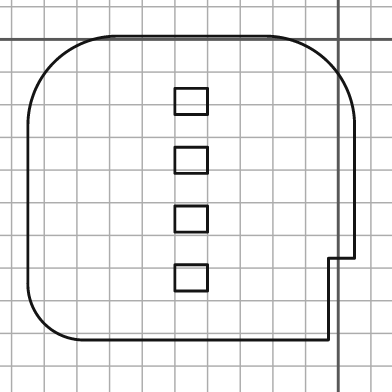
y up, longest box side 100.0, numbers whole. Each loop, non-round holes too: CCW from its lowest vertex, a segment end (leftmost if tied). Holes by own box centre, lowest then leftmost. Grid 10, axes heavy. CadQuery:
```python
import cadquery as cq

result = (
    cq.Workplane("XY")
    .moveTo(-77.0, -92.0)
    .lineTo(-3.0, -92.0)
    .lineTo(-3.0, -67.0)
    .lineTo(5.0, -67.0)
    .lineTo(5.0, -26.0)
    .threePointArc((-3.0, -7.0), (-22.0, 1.0))
    .lineTo(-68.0, 1.0)
    .threePointArc((-87.0, -7.0), (-95.0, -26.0))
    .lineTo(-95.0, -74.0)
    .threePointArc((-90.0, -87.0), (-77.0, -92.0))
    .close()
    .moveTo(-50.0, -77.0)
    .lineTo(-40.0, -77.0)
    .lineTo(-40.0, -69.0)
    .lineTo(-50.0, -69.0)
    .close()
    .moveTo(-50.0, -59.0)
    .lineTo(-40.0, -59.0)
    .lineTo(-40.0, -51.0)
    .lineTo(-50.0, -51.0)
    .close()
    .moveTo(-50.0, -41.0)
    .lineTo(-40.0, -41.0)
    .lineTo(-40.0, -33.0)
    .lineTo(-50.0, -33.0)
    .close()
    .moveTo(-50.0, -23.0)
    .lineTo(-40.0, -23.0)
    .lineTo(-40.0, -15.0)
    .lineTo(-50.0, -15.0)
    .close()
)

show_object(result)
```